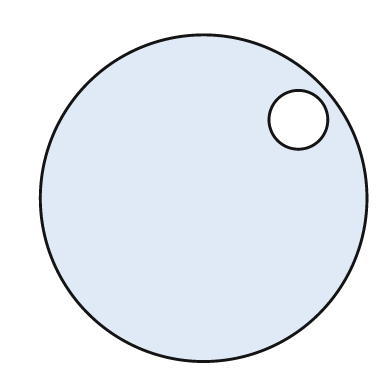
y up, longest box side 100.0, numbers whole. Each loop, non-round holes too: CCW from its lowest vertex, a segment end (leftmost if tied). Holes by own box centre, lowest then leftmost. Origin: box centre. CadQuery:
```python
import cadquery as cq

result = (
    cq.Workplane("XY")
    .moveTo(0.0, 0.0)
    .circle(50.0)
    .moveTo(29.0, 24.0)
    .circle(9.0)
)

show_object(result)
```